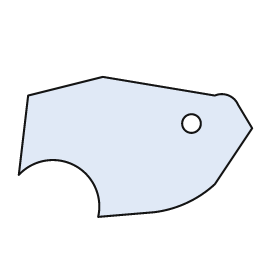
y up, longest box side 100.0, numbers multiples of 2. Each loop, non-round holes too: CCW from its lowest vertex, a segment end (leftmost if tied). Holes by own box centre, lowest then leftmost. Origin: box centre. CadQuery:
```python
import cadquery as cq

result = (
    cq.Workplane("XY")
    .moveTo(-16.0, -30.0)
    .lineTo(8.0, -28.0)
    .threePointArc((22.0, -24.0), (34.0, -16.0))
    .lineTo(50.0, 8.0)
    .lineTo(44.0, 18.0)
    .threePointArc((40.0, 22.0), (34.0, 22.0))
    .lineTo(-14.0, 30.0)
    .lineTo(-46.0, 22.0)
    .lineTo(-50.0, -12.0)
    .threePointArc((-26.0, -8.0), (-16.0, -30.0))
    .close()
    .moveTo(24.0, 10.0)
    .circle(4.0)
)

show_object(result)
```